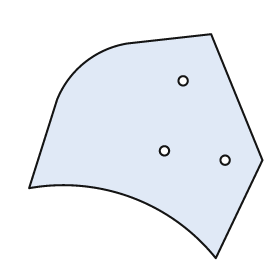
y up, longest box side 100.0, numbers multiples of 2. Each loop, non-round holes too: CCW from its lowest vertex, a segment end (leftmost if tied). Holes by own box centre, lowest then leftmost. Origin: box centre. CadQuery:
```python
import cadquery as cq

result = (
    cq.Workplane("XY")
    .moveTo(30.0, -48.0)
    .lineTo(50.0, -6.0)
    .lineTo(28.0, 48.0)
    .lineTo(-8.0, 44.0)
    .threePointArc((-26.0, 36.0), (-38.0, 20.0))
    .lineTo(-50.0, -18.0)
    .threePointArc((-6.0, -22.0), (30.0, -48.0))
    .close()
    .moveTo(34.0, -6.0)
    .circle(2.0)
    .moveTo(8.0, -2.0)
    .circle(2.0)
    .moveTo(16.0, 28.0)
    .circle(2.0)
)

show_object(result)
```